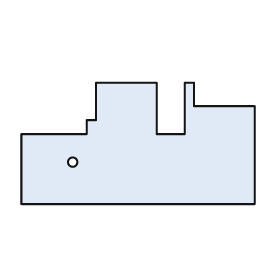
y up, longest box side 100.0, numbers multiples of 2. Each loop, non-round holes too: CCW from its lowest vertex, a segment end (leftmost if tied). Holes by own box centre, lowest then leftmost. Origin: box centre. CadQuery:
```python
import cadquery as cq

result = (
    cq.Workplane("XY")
    .moveTo(-50.0, -26.0)
    .lineTo(50.0, -26.0)
    .lineTo(50.0, 16.0)
    .lineTo(24.0, 16.0)
    .lineTo(24.0, 26.0)
    .lineTo(20.0, 26.0)
    .lineTo(20.0, 4.0)
    .lineTo(8.0, 4.0)
    .lineTo(8.0, 26.0)
    .lineTo(-18.0, 26.0)
    .lineTo(-18.0, 10.0)
    .lineTo(-22.0, 10.0)
    .lineTo(-22.0, 4.0)
    .lineTo(-50.0, 4.0)
    .close()
    .moveTo(-28.0, -8.0)
    .circle(2.0)
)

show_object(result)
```